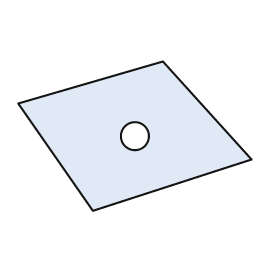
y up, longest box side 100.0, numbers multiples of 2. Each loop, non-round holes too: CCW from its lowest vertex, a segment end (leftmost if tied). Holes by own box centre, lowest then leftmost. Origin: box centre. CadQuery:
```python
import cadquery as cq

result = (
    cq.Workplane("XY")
    .moveTo(-18.0, -32.0)
    .lineTo(50.0, -10.0)
    .lineTo(12.0, 32.0)
    .lineTo(-50.0, 14.0)
    .close()
    .moveTo(0.0, 0.0)
    .circle(6.0)
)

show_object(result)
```